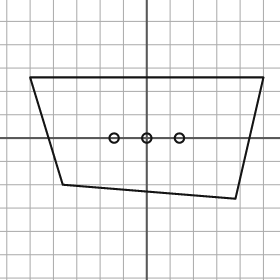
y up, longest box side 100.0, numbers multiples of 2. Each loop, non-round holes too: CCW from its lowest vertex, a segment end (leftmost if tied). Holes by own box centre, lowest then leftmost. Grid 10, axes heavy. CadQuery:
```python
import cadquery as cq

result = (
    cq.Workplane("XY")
    .moveTo(38.0, -26.0)
    .lineTo(50.0, 26.0)
    .lineTo(-50.0, 26.0)
    .lineTo(-36.0, -20.0)
    .close()
    .moveTo(-14.0, 0.0)
    .circle(2.0)
    .moveTo(0.0, 0.0)
    .circle(2.0)
    .moveTo(14.0, 0.0)
    .circle(2.0)
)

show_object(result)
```